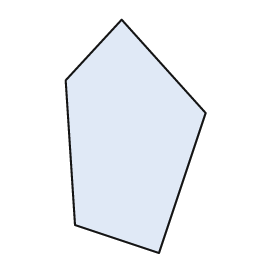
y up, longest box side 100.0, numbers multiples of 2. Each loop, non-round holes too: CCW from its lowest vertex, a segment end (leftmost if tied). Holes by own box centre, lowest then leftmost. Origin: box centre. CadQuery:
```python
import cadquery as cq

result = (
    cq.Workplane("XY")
    .moveTo(10.0, -50.0)
    .lineTo(30.0, 10.0)
    .lineTo(-6.0, 50.0)
    .lineTo(-30.0, 24.0)
    .lineTo(-26.0, -38.0)
    .close()
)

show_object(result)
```